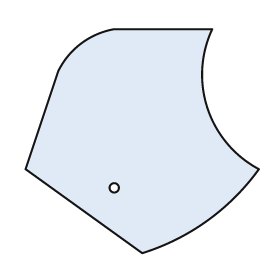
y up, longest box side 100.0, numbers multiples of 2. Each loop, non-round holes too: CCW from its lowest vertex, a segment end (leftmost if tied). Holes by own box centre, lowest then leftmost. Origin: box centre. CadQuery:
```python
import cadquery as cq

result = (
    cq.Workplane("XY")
    .moveTo(0.0, -48.0)
    .threePointArc((28.0, -34.0), (50.0, -12.0))
    .threePointArc((28.0, 14.0), (30.0, 48.0))
    .lineTo(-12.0, 48.0)
    .threePointArc((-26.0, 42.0), (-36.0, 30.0))
    .lineTo(-50.0, -12.0)
    .close()
    .moveTo(-12.0, -20.0)
    .circle(2.0)
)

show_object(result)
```